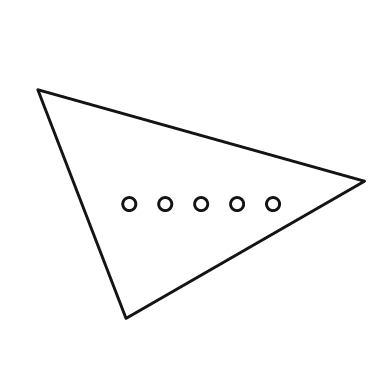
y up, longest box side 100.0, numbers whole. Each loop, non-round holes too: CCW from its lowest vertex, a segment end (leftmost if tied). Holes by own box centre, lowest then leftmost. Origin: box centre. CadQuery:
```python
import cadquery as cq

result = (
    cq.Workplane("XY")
    .moveTo(-23.0, -35.0)
    .lineTo(50.0, 7.0)
    .lineTo(-50.0, 35.0)
    .close()
    .moveTo(-22.0, 0.0)
    .circle(2.0)
    .moveTo(-11.0, 0.0)
    .circle(2.0)
    .moveTo(0.0, 0.0)
    .circle(2.0)
    .moveTo(11.0, 0.0)
    .circle(2.0)
    .moveTo(22.0, 0.0)
    .circle(2.0)
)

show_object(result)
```